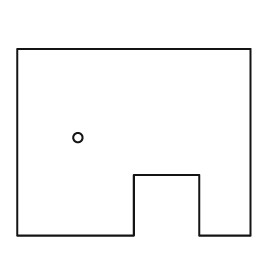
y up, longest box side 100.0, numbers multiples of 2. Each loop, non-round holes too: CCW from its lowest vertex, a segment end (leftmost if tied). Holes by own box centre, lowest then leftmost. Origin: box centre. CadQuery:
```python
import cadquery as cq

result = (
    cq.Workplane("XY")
    .moveTo(-50.0, -40.0)
    .lineTo(0.0, -40.0)
    .lineTo(0.0, -14.0)
    .lineTo(28.0, -14.0)
    .lineTo(28.0, -40.0)
    .lineTo(50.0, -40.0)
    .lineTo(50.0, 40.0)
    .lineTo(-50.0, 40.0)
    .close()
    .moveTo(-24.0, 2.0)
    .circle(2.0)
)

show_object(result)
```